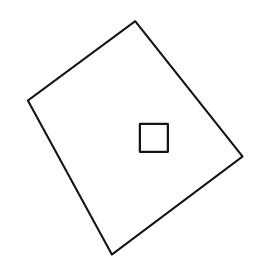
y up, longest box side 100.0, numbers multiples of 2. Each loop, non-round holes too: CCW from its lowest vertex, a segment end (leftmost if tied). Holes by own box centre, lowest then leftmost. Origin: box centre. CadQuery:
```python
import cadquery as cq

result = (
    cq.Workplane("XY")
    .moveTo(-10.0, -50.0)
    .lineTo(46.0, -8.0)
    .lineTo(0.0, 50.0)
    .lineTo(-46.0, 16.0)
    .close()
    .moveTo(2.0, -6.0)
    .lineTo(14.0, -6.0)
    .lineTo(14.0, 6.0)
    .lineTo(2.0, 6.0)
    .close()
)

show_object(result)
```